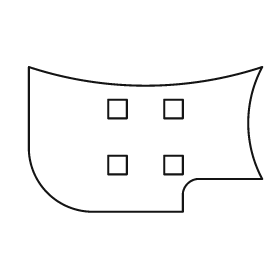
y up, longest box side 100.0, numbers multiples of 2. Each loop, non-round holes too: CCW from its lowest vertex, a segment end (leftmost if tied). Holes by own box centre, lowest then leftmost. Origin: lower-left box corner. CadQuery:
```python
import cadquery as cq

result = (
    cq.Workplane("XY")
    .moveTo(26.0, 0.0)
    .lineTo(66.0, 0.0)
    .lineTo(66.0, 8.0)
    .threePointArc((68.0, 12.0), (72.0, 14.0))
    .lineTo(100.0, 14.0)
    .threePointArc((94.0, 38.0), (100.0, 62.0))
    .threePointArc((50.0, 54.0), (0.0, 62.0))
    .lineTo(0.0, 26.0)
    .threePointArc((8.0, 8.0), (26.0, 0.0))
    .close()
    .moveTo(34.0, 16.0)
    .lineTo(42.0, 16.0)
    .lineTo(42.0, 24.0)
    .lineTo(34.0, 24.0)
    .close()
    .moveTo(58.0, 16.0)
    .lineTo(66.0, 16.0)
    .lineTo(66.0, 24.0)
    .lineTo(58.0, 24.0)
    .close()
    .moveTo(34.0, 40.0)
    .lineTo(42.0, 40.0)
    .lineTo(42.0, 48.0)
    .lineTo(34.0, 48.0)
    .close()
    .moveTo(58.0, 40.0)
    .lineTo(66.0, 40.0)
    .lineTo(66.0, 48.0)
    .lineTo(58.0, 48.0)
    .close()
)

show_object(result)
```